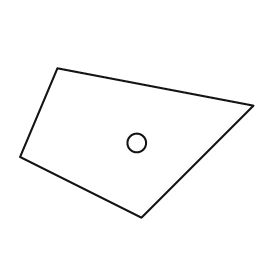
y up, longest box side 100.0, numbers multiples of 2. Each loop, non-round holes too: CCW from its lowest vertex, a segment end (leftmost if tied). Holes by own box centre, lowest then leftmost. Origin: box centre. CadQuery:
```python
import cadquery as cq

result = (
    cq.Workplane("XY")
    .moveTo(2.0, -32.0)
    .lineTo(50.0, 16.0)
    .lineTo(-34.0, 32.0)
    .lineTo(-50.0, -6.0)
    .close()
    .moveTo(0.0, 0.0)
    .circle(4.0)
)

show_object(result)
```